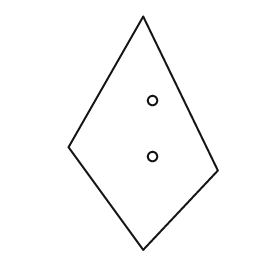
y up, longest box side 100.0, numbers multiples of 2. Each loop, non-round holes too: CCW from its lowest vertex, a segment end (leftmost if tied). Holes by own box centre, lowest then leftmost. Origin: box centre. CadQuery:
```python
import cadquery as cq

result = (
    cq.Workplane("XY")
    .moveTo(0.0, -50.0)
    .lineTo(32.0, -16.0)
    .lineTo(0.0, 50.0)
    .lineTo(-32.0, -6.0)
    .close()
    .moveTo(4.0, -10.0)
    .circle(2.0)
    .moveTo(4.0, 14.0)
    .circle(2.0)
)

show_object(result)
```